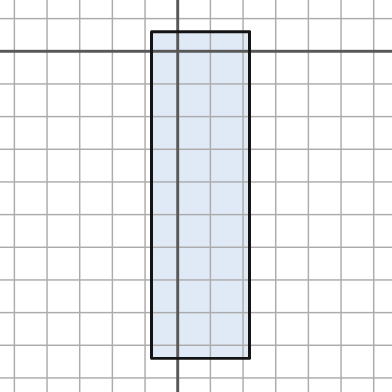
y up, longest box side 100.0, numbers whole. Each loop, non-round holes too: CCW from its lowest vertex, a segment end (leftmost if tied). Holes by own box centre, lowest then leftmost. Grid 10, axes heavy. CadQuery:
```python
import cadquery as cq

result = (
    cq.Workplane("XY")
    .moveTo(-8.0, -94.0)
    .lineTo(22.0, -94.0)
    .lineTo(22.0, 6.0)
    .lineTo(-8.0, 6.0)
    .close()
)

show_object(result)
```